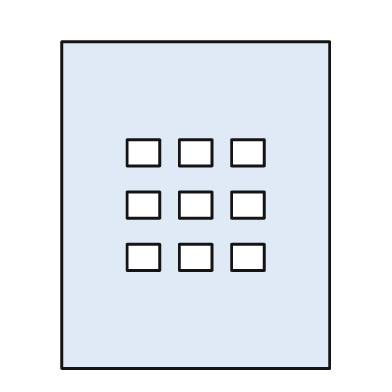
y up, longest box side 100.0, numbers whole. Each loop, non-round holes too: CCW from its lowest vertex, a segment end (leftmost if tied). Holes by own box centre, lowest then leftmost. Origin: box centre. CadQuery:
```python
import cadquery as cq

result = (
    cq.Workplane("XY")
    .moveTo(-41.0, -50.0)
    .lineTo(41.0, -50.0)
    .lineTo(41.0, 50.0)
    .lineTo(-41.0, 50.0)
    .close()
    .moveTo(-21.0, -20.0)
    .lineTo(-11.0, -20.0)
    .lineTo(-11.0, -12.0)
    .lineTo(-21.0, -12.0)
    .close()
    .moveTo(-5.0, -20.0)
    .lineTo(5.0, -20.0)
    .lineTo(5.0, -12.0)
    .lineTo(-5.0, -12.0)
    .close()
    .moveTo(11.0, -20.0)
    .lineTo(21.0, -20.0)
    .lineTo(21.0, -12.0)
    .lineTo(11.0, -12.0)
    .close()
    .moveTo(-21.0, -4.0)
    .lineTo(-11.0, -4.0)
    .lineTo(-11.0, 4.0)
    .lineTo(-21.0, 4.0)
    .close()
    .moveTo(-5.0, -4.0)
    .lineTo(5.0, -4.0)
    .lineTo(5.0, 4.0)
    .lineTo(-5.0, 4.0)
    .close()
    .moveTo(11.0, -4.0)
    .lineTo(21.0, -4.0)
    .lineTo(21.0, 4.0)
    .lineTo(11.0, 4.0)
    .close()
    .moveTo(-21.0, 12.0)
    .lineTo(-11.0, 12.0)
    .lineTo(-11.0, 20.0)
    .lineTo(-21.0, 20.0)
    .close()
    .moveTo(-5.0, 12.0)
    .lineTo(5.0, 12.0)
    .lineTo(5.0, 20.0)
    .lineTo(-5.0, 20.0)
    .close()
    .moveTo(11.0, 12.0)
    .lineTo(21.0, 12.0)
    .lineTo(21.0, 20.0)
    .lineTo(11.0, 20.0)
    .close()
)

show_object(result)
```